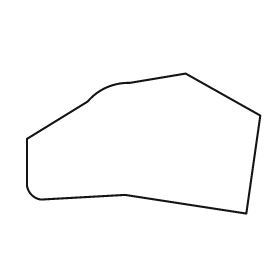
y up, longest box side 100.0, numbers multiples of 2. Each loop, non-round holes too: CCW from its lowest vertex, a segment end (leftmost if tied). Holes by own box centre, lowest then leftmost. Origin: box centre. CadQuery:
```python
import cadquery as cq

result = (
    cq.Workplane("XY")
    .moveTo(44.0, -30.0)
    .lineTo(50.0, 12.0)
    .lineTo(18.0, 30.0)
    .lineTo(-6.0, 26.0)
    .threePointArc((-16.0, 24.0), (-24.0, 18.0))
    .lineTo(-50.0, 2.0)
    .lineTo(-50.0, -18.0)
    .threePointArc((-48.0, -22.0), (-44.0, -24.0))
    .lineTo(-8.0, -22.0)
    .close()
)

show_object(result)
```